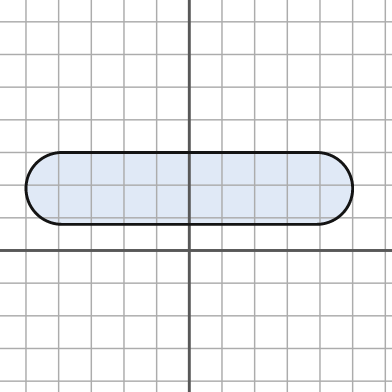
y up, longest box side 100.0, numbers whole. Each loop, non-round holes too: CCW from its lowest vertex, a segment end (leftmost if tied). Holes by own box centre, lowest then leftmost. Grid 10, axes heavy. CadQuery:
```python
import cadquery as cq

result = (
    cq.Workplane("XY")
    .moveTo(-39.0, 8.0)
    .lineTo(39.0, 8.0)
    .threePointArc((50.0, 19.0), (39.0, 30.0))
    .lineTo(-39.0, 30.0)
    .threePointArc((-50.0, 19.0), (-39.0, 8.0))
    .close()
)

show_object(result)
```